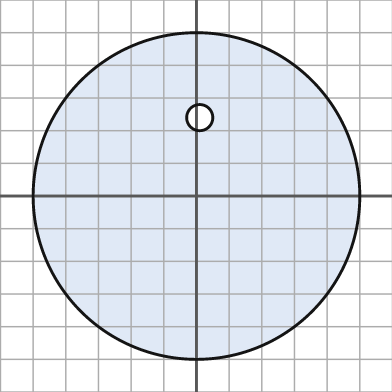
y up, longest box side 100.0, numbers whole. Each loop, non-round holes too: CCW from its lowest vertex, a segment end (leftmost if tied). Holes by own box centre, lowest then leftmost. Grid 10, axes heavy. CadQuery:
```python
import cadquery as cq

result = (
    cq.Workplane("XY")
    .moveTo(0.0, 0.0)
    .circle(50.0)
    .moveTo(1.0, 24.0)
    .circle(4.0)
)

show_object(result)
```